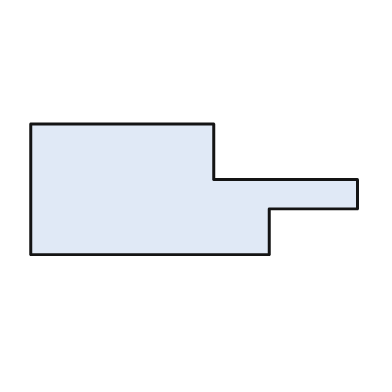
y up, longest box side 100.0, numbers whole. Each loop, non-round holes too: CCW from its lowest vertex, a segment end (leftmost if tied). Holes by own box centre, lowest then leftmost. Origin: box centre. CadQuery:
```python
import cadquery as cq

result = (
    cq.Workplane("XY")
    .moveTo(-50.0, -20.0)
    .lineTo(23.0, -20.0)
    .lineTo(23.0, -6.0)
    .lineTo(50.0, -6.0)
    .lineTo(50.0, 3.0)
    .lineTo(6.0, 3.0)
    .lineTo(6.0, 20.0)
    .lineTo(-50.0, 20.0)
    .close()
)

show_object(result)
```